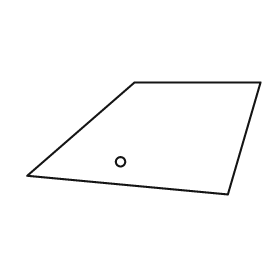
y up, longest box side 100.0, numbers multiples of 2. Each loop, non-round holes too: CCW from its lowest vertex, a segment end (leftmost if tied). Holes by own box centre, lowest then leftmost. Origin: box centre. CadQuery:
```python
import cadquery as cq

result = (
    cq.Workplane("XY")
    .moveTo(36.0, -24.0)
    .lineTo(50.0, 24.0)
    .lineTo(-4.0, 24.0)
    .lineTo(-50.0, -16.0)
    .close()
    .moveTo(-10.0, -10.0)
    .circle(2.0)
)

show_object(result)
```